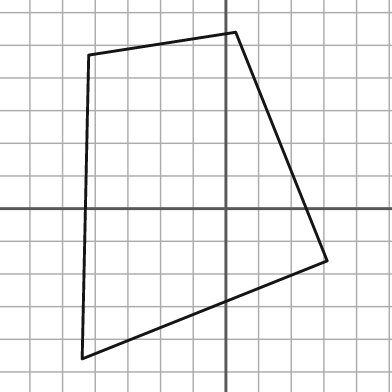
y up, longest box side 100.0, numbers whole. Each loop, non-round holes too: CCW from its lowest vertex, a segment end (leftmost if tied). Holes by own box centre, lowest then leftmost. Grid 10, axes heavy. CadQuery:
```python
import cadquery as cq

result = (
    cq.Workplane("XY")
    .moveTo(-44.0, -46.0)
    .lineTo(31.0, -16.0)
    .lineTo(3.0, 54.0)
    .lineTo(-42.0, 47.0)
    .close()
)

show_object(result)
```